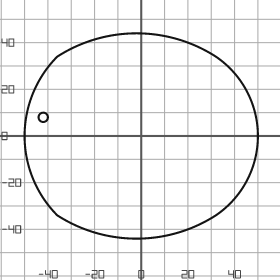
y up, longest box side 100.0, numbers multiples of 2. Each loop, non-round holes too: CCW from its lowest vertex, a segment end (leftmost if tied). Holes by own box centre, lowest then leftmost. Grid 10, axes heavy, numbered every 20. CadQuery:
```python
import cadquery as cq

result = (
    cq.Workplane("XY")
    .moveTo(-36.0, -34.0)
    .threePointArc((-2.0, -44.0), (32.0, -34.0))
    .threePointArc((50.0, 0.0), (32.0, 34.0))
    .threePointArc((-2.0, 44.0), (-36.0, 34.0))
    .threePointArc((-50.0, 0.0), (-36.0, -34.0))
    .close()
    .moveTo(-42.0, 8.0)
    .circle(2.0)
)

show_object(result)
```